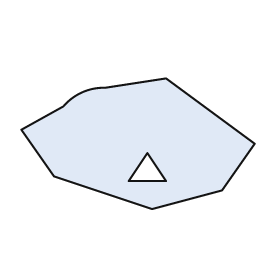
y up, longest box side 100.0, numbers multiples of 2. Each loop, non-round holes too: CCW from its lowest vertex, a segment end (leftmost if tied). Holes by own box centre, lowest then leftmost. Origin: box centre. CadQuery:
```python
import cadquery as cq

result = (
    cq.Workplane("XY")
    .moveTo(6.0, -28.0)
    .lineTo(36.0, -20.0)
    .lineTo(50.0, 0.0)
    .lineTo(12.0, 28.0)
    .lineTo(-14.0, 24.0)
    .threePointArc((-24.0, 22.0), (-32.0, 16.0))
    .lineTo(-50.0, 6.0)
    .lineTo(-36.0, -14.0)
    .close()
    .moveTo(-4.0, -16.0)
    .lineTo(12.0, -16.0)
    .lineTo(4.0, -4.0)
    .close()
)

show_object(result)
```